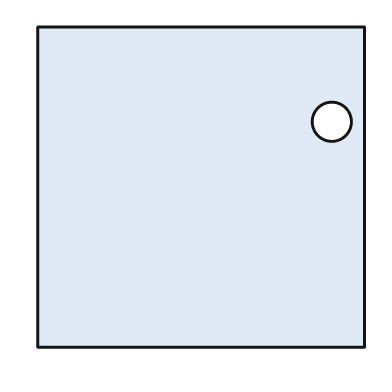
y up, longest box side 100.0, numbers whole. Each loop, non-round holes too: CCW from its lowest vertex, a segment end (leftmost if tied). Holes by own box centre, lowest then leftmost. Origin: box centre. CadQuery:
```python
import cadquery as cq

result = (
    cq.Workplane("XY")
    .moveTo(-50.0, -49.0)
    .lineTo(50.0, -49.0)
    .lineTo(50.0, 49.0)
    .lineTo(-50.0, 49.0)
    .close()
    .moveTo(40.0, 20.0)
    .circle(6.0)
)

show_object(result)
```